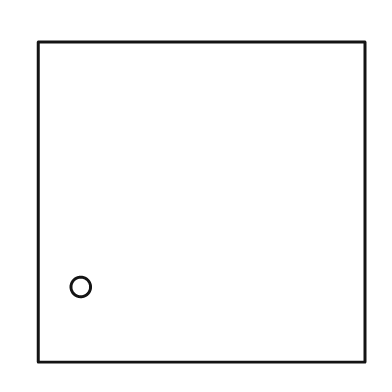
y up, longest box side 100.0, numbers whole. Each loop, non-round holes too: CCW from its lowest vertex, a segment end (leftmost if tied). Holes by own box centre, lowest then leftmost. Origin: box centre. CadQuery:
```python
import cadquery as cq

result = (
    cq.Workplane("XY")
    .moveTo(-50.0, -49.0)
    .lineTo(50.0, -49.0)
    .lineTo(50.0, 49.0)
    .lineTo(-50.0, 49.0)
    .close()
    .moveTo(-37.0, -26.0)
    .circle(3.0)
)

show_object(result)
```